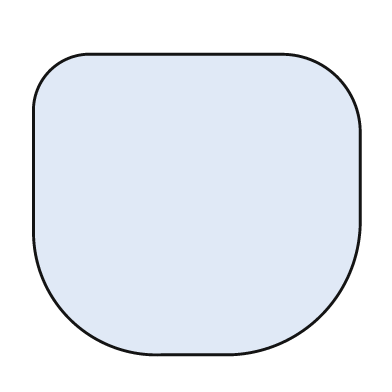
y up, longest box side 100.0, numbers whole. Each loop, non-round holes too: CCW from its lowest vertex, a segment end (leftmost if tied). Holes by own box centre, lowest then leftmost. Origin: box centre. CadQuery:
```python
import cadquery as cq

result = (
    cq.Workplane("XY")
    .moveTo(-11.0, -46.0)
    .lineTo(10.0, -46.0)
    .threePointArc((38.0, -34.0), (50.0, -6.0))
    .lineTo(50.0, 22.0)
    .threePointArc((43.0, 39.0), (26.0, 46.0))
    .lineTo(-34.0, 46.0)
    .threePointArc((-45.0, 41.0), (-50.0, 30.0))
    .lineTo(-50.0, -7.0)
    .threePointArc((-39.0, -35.0), (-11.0, -46.0))
    .close()
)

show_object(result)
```